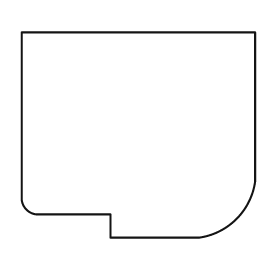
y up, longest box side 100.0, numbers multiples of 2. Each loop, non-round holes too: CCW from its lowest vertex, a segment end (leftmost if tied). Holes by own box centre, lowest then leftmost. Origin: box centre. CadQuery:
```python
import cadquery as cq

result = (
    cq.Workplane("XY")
    .moveTo(-12.0, -44.0)
    .lineTo(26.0, -44.0)
    .threePointArc((42.0, -36.0), (50.0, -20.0))
    .lineTo(50.0, 44.0)
    .lineTo(-50.0, 44.0)
    .lineTo(-50.0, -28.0)
    .threePointArc((-48.0, -32.0), (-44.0, -34.0))
    .lineTo(-12.0, -34.0)
    .close()
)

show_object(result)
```